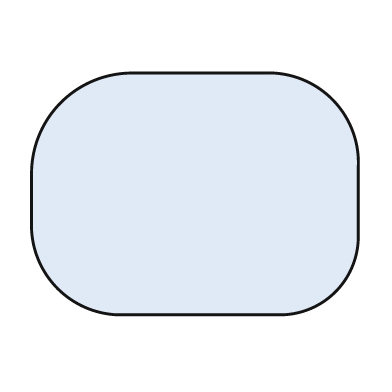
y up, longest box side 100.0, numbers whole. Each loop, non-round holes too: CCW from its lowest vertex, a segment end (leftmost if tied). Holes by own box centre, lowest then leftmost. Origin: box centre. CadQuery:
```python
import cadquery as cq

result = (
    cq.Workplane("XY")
    .moveTo(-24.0, -37.0)
    .lineTo(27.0, -37.0)
    .threePointArc((43.0, -30.0), (50.0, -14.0))
    .lineTo(50.0, 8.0)
    .threePointArc((42.0, 29.0), (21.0, 37.0))
    .lineTo(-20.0, 37.0)
    .threePointArc((-41.0, 28.0), (-50.0, 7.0))
    .lineTo(-50.0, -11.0)
    .threePointArc((-42.0, -29.0), (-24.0, -37.0))
    .close()
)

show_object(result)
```